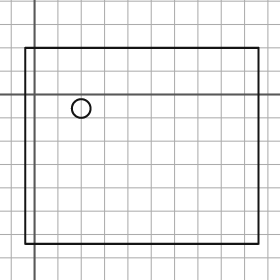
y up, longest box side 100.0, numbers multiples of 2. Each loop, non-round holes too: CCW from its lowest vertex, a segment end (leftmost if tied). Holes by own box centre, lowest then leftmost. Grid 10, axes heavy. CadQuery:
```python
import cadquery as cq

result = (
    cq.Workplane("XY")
    .moveTo(-4.0, -64.0)
    .lineTo(96.0, -64.0)
    .lineTo(96.0, 20.0)
    .lineTo(-4.0, 20.0)
    .close()
    .moveTo(20.0, -6.0)
    .circle(4.0)
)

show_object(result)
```